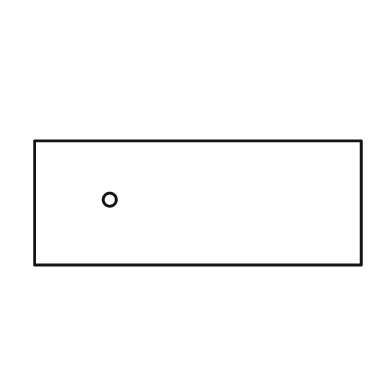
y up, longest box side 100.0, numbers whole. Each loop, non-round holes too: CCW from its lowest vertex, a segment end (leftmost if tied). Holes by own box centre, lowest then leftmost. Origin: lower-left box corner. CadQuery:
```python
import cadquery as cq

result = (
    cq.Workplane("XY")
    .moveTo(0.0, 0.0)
    .lineTo(100.0, 0.0)
    .lineTo(100.0, 38.0)
    .lineTo(0.0, 38.0)
    .close()
    .moveTo(23.0, 20.0)
    .circle(2.0)
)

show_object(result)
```